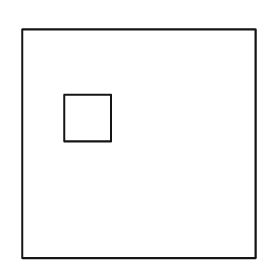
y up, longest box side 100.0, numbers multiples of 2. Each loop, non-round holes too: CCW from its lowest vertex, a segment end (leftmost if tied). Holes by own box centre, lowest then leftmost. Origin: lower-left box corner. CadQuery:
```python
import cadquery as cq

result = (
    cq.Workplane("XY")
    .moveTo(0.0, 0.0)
    .lineTo(100.0, 0.0)
    .lineTo(100.0, 98.0)
    .lineTo(0.0, 98.0)
    .close()
    .moveTo(18.0, 50.0)
    .lineTo(38.0, 50.0)
    .lineTo(38.0, 70.0)
    .lineTo(18.0, 70.0)
    .close()
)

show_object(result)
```